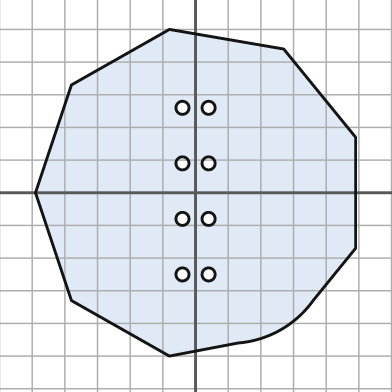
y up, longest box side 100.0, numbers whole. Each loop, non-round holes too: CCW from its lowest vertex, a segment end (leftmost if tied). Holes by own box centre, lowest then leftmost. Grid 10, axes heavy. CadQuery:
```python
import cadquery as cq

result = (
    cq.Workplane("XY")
    .moveTo(-8.0, -50.0)
    .lineTo(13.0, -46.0)
    .threePointArc((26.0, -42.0), (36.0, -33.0))
    .lineTo(49.0, -17.0)
    .lineTo(49.0, 17.0)
    .lineTo(27.0, 44.0)
    .lineTo(-8.0, 50.0)
    .lineTo(-38.0, 33.0)
    .lineTo(-49.0, 0.0)
    .lineTo(-38.0, -33.0)
    .close()
    .moveTo(-4.0, -25.0)
    .circle(2.0)
    .moveTo(4.0, -25.0)
    .circle(2.0)
    .moveTo(-4.0, -8.0)
    .circle(2.0)
    .moveTo(4.0, -8.0)
    .circle(2.0)
    .moveTo(-4.0, 9.0)
    .circle(2.0)
    .moveTo(4.0, 9.0)
    .circle(2.0)
    .moveTo(-4.0, 26.0)
    .circle(2.0)
    .moveTo(4.0, 26.0)
    .circle(2.0)
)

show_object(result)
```